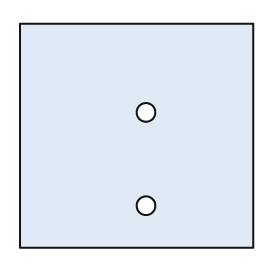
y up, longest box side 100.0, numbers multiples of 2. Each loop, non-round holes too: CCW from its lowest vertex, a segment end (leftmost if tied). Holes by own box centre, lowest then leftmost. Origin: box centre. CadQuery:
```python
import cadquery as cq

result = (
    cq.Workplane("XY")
    .moveTo(-50.0, -48.0)
    .lineTo(50.0, -48.0)
    .lineTo(50.0, 48.0)
    .lineTo(-50.0, 48.0)
    .close()
    .moveTo(4.0, -30.0)
    .circle(4.0)
    .moveTo(4.0, 10.0)
    .circle(4.0)
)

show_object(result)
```